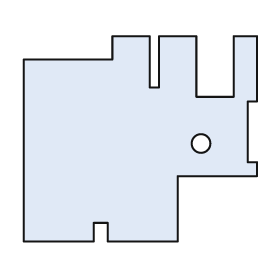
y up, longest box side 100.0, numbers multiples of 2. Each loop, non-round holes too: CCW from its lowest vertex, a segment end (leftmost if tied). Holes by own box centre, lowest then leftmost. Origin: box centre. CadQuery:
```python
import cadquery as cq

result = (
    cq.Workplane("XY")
    .moveTo(-50.0, -44.0)
    .lineTo(-20.0, -44.0)
    .lineTo(-20.0, -36.0)
    .lineTo(-14.0, -36.0)
    .lineTo(-14.0, -44.0)
    .lineTo(16.0, -44.0)
    .lineTo(16.0, -16.0)
    .lineTo(50.0, -16.0)
    .lineTo(50.0, -10.0)
    .lineTo(46.0, -10.0)
    .lineTo(46.0, 16.0)
    .lineTo(50.0, 16.0)
    .lineTo(50.0, 44.0)
    .lineTo(40.0, 44.0)
    .lineTo(40.0, 18.0)
    .lineTo(24.0, 18.0)
    .lineTo(24.0, 44.0)
    .lineTo(8.0, 44.0)
    .lineTo(8.0, 22.0)
    .lineTo(4.0, 22.0)
    .lineTo(4.0, 44.0)
    .lineTo(-12.0, 44.0)
    .lineTo(-12.0, 34.0)
    .lineTo(-50.0, 34.0)
    .close()
    .moveTo(26.0, -2.0)
    .circle(4.0)
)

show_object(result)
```